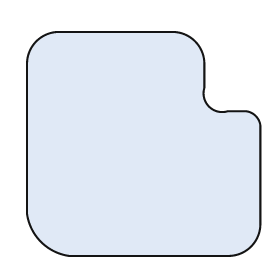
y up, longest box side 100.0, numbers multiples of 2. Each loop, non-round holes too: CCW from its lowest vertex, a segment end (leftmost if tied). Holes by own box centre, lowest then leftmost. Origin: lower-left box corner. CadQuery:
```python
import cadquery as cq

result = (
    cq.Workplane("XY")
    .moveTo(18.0, 0.0)
    .lineTo(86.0, 0.0)
    .threePointArc((96.0, 4.0), (100.0, 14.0))
    .lineTo(100.0, 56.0)
    .threePointArc((98.0, 60.0), (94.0, 62.0))
    .lineTo(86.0, 62.0)
    .threePointArc((78.0, 64.0), (76.0, 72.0))
    .lineTo(76.0, 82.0)
    .threePointArc((72.0, 92.0), (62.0, 96.0))
    .lineTo(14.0, 96.0)
    .threePointArc((4.0, 92.0), (0.0, 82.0))
    .lineTo(0.0, 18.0)
    .threePointArc((6.0, 6.0), (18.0, 0.0))
    .close()
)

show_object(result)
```